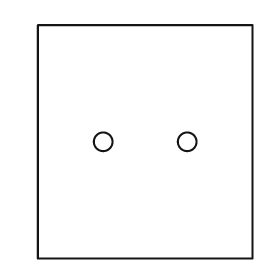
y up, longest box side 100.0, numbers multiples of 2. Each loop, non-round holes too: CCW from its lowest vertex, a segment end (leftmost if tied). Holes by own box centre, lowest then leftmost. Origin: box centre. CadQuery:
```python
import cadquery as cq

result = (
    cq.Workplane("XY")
    .moveTo(-46.0, -50.0)
    .lineTo(46.0, -50.0)
    .lineTo(46.0, 50.0)
    .lineTo(-46.0, 50.0)
    .close()
    .moveTo(-18.0, 0.0)
    .circle(4.0)
    .moveTo(18.0, 0.0)
    .circle(4.0)
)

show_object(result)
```